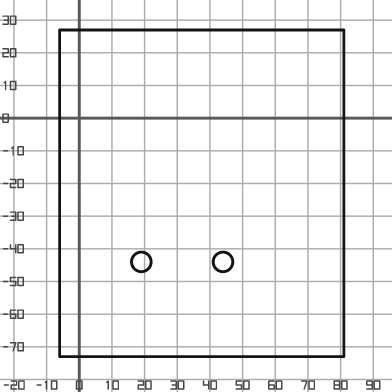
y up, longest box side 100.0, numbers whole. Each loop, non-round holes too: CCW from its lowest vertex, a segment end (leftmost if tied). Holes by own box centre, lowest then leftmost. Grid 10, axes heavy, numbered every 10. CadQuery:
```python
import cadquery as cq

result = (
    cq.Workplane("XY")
    .moveTo(-6.0, -73.0)
    .lineTo(81.0, -73.0)
    .lineTo(81.0, 27.0)
    .lineTo(-6.0, 27.0)
    .close()
    .moveTo(19.0, -44.0)
    .circle(3.0)
    .moveTo(44.0, -44.0)
    .circle(3.0)
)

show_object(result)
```